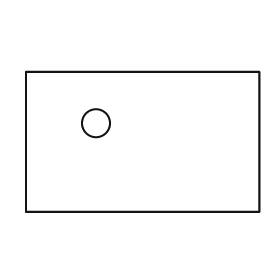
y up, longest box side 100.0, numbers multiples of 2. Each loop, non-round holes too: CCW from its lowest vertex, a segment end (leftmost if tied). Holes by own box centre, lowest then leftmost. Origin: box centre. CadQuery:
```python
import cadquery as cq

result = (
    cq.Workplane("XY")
    .moveTo(-50.0, -30.0)
    .lineTo(50.0, -30.0)
    .lineTo(50.0, 30.0)
    .lineTo(-50.0, 30.0)
    .close()
    .moveTo(-20.0, 8.0)
    .circle(6.0)
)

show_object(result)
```